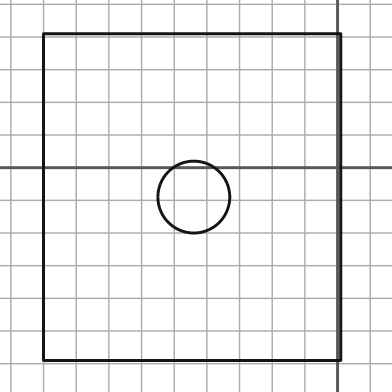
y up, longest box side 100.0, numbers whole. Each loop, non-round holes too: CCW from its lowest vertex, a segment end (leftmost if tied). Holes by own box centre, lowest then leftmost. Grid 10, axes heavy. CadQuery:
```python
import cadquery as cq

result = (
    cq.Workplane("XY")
    .moveTo(-90.0, -59.0)
    .lineTo(1.0, -59.0)
    .lineTo(1.0, 41.0)
    .lineTo(-90.0, 41.0)
    .close()
    .moveTo(-44.0, -9.0)
    .circle(11.0)
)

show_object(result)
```